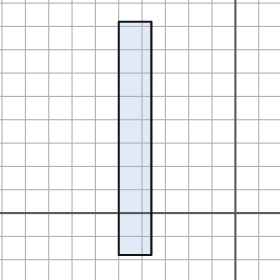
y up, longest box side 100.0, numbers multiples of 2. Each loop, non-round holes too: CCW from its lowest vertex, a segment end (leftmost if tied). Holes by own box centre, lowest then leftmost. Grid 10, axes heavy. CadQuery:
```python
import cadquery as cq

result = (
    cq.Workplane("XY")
    .moveTo(-50.0, -18.0)
    .lineTo(-36.0, -18.0)
    .lineTo(-36.0, 82.0)
    .lineTo(-50.0, 82.0)
    .close()
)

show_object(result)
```